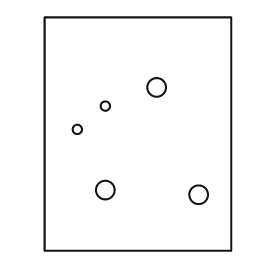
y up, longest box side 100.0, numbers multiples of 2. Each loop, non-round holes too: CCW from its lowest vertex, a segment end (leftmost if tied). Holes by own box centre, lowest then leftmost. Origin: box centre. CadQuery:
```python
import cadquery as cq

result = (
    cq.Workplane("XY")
    .moveTo(-40.0, -50.0)
    .lineTo(40.0, -50.0)
    .lineTo(40.0, 50.0)
    .lineTo(-40.0, 50.0)
    .close()
    .moveTo(26.0, -26.0)
    .circle(4.0)
    .moveTo(-14.0, -24.0)
    .circle(4.0)
    .moveTo(-26.0, 2.0)
    .circle(2.0)
    .moveTo(-14.0, 12.0)
    .circle(2.0)
    .moveTo(8.0, 20.0)
    .circle(4.0)
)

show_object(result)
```